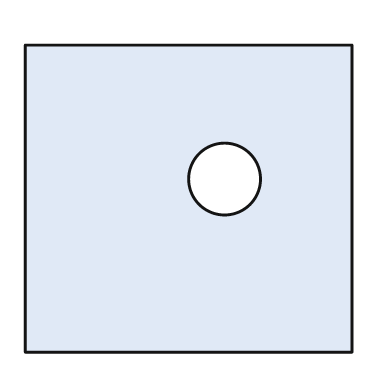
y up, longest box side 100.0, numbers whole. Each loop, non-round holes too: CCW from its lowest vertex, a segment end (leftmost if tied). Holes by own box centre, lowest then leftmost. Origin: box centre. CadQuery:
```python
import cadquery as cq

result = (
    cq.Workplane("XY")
    .moveTo(-50.0, -47.0)
    .lineTo(50.0, -47.0)
    .lineTo(50.0, 47.0)
    .lineTo(-50.0, 47.0)
    .close()
    .moveTo(11.0, 6.0)
    .circle(11.0)
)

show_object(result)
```